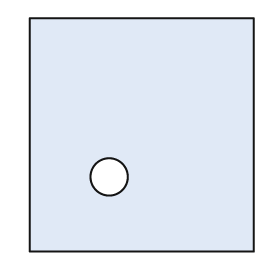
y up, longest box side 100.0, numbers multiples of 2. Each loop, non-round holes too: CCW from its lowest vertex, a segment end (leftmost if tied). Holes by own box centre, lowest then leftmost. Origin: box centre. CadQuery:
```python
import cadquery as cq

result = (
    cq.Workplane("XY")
    .moveTo(-48.0, -50.0)
    .lineTo(48.0, -50.0)
    .lineTo(48.0, 50.0)
    .lineTo(-48.0, 50.0)
    .close()
    .moveTo(-14.0, -18.0)
    .circle(8.0)
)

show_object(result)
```